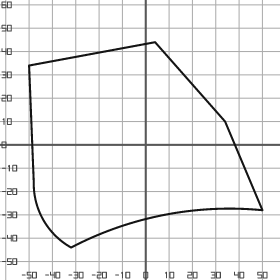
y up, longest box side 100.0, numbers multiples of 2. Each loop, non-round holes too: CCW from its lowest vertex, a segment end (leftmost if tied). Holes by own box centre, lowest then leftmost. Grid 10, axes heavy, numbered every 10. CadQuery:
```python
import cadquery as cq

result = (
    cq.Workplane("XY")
    .moveTo(-32.0, -44.0)
    .threePointArc((8.0, -30.0), (50.0, -28.0))
    .lineTo(34.0, 10.0)
    .lineTo(4.0, 44.0)
    .lineTo(-50.0, 34.0)
    .lineTo(-48.0, -16.0)
    .threePointArc((-44.0, -32.0), (-32.0, -44.0))
    .close()
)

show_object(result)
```